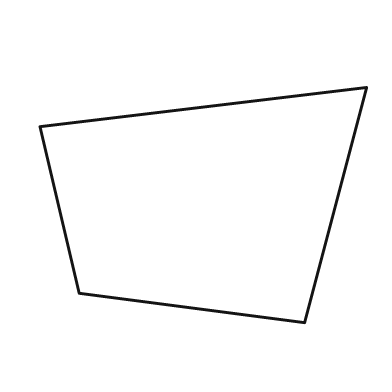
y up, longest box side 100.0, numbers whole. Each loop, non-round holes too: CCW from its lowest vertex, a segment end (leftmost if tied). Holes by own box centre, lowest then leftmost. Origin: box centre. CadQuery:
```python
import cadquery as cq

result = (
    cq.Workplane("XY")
    .moveTo(31.0, -36.0)
    .lineTo(50.0, 36.0)
    .lineTo(-50.0, 24.0)
    .lineTo(-38.0, -27.0)
    .close()
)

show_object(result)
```